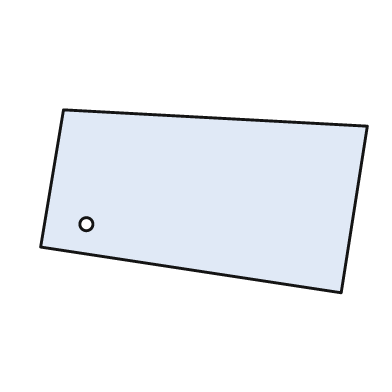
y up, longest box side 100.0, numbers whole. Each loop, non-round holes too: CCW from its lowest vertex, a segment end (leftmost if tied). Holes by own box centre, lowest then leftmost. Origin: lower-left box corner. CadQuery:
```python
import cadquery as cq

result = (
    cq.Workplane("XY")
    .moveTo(92.0, 0.0)
    .lineTo(100.0, 51.0)
    .lineTo(7.0, 56.0)
    .lineTo(0.0, 14.0)
    .close()
    .moveTo(14.0, 21.0)
    .circle(2.0)
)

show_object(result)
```